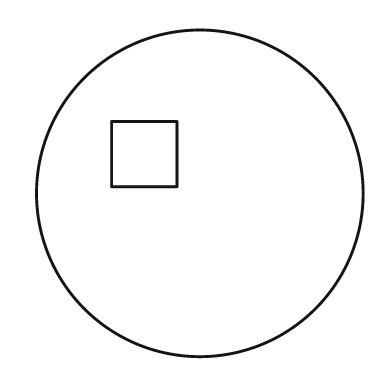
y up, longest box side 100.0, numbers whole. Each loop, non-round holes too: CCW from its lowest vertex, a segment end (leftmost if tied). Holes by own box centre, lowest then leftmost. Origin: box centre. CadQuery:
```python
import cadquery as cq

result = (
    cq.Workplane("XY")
    .moveTo(0.0, 0.0)
    .circle(50.0)
    .moveTo(-27.0, 2.0)
    .lineTo(-7.0, 2.0)
    .lineTo(-7.0, 22.0)
    .lineTo(-27.0, 22.0)
    .close()
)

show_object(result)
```